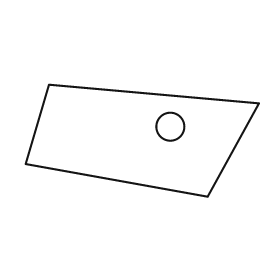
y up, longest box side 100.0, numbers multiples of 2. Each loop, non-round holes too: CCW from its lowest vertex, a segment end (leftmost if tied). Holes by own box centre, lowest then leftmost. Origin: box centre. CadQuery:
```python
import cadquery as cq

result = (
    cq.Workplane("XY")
    .moveTo(28.0, -24.0)
    .lineTo(50.0, 16.0)
    .lineTo(-40.0, 24.0)
    .lineTo(-50.0, -10.0)
    .close()
    .moveTo(12.0, 6.0)
    .circle(6.0)
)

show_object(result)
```